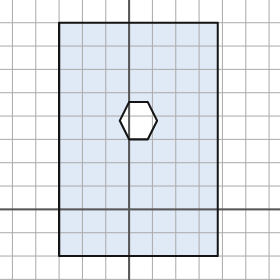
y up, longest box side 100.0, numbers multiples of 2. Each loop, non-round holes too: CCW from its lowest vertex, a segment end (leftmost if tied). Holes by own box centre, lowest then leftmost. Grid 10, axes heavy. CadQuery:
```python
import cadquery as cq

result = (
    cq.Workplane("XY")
    .moveTo(-30.0, -20.0)
    .lineTo(38.0, -20.0)
    .lineTo(38.0, 80.0)
    .lineTo(-30.0, 80.0)
    .close()
    .moveTo(0.0, 30.0)
    .lineTo(8.0, 30.0)
    .lineTo(12.0, 38.0)
    .lineTo(8.0, 46.0)
    .lineTo(0.0, 46.0)
    .lineTo(-4.0, 38.0)
    .close()
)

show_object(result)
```